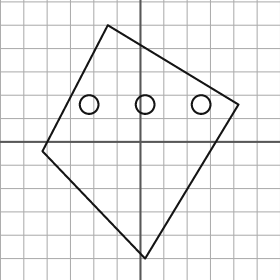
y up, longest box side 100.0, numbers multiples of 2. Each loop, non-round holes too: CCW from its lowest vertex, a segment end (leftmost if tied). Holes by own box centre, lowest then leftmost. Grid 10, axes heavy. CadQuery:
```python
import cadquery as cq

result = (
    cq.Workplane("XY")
    .moveTo(2.0, -50.0)
    .lineTo(42.0, 16.0)
    .lineTo(-14.0, 50.0)
    .lineTo(-42.0, -4.0)
    .close()
    .moveTo(-22.0, 16.0)
    .circle(4.0)
    .moveTo(2.0, 16.0)
    .circle(4.0)
    .moveTo(26.0, 16.0)
    .circle(4.0)
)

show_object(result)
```